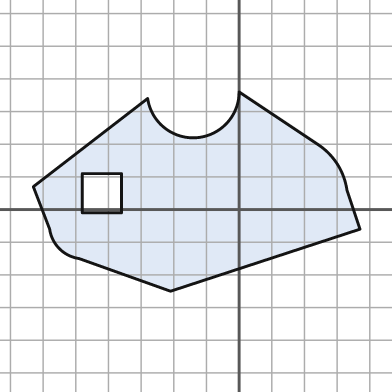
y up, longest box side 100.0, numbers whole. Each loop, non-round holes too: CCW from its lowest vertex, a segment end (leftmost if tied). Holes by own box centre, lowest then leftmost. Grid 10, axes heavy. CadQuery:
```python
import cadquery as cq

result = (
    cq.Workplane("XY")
    .moveTo(-21.0, -25.0)
    .lineTo(37.0, -6.0)
    .lineTo(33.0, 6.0)
    .threePointArc((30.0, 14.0), (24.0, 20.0))
    .lineTo(0.0, 36.0)
    .threePointArc((-13.0, 22.0), (-28.0, 34.0))
    .lineTo(-63.0, 7.0)
    .lineTo(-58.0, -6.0)
    .threePointArc((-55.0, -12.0), (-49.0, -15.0))
    .close()
    .moveTo(-48.0, -1.0)
    .lineTo(-36.0, -1.0)
    .lineTo(-36.0, 11.0)
    .lineTo(-48.0, 11.0)
    .close()
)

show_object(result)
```